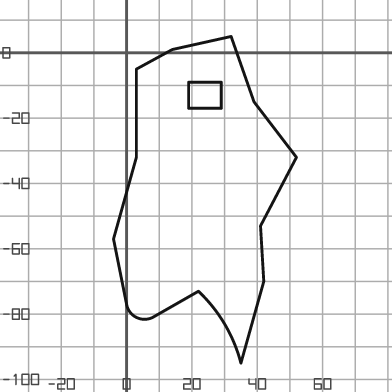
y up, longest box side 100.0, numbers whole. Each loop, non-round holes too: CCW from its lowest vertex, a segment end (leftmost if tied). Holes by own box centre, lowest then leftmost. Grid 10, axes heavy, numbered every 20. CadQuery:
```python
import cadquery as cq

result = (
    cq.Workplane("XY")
    .moveTo(35.0, -95.0)
    .lineTo(42.0, -70.0)
    .lineTo(41.0, -53.0)
    .lineTo(52.0, -32.0)
    .lineTo(39.0, -15.0)
    .lineTo(32.0, 5.0)
    .lineTo(14.0, 1.0)
    .lineTo(3.0, -5.0)
    .lineTo(3.0, -32.0)
    .lineTo(-4.0, -57.0)
    .lineTo(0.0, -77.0)
    .threePointArc((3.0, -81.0), (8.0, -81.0))
    .lineTo(22.0, -73.0)
    .threePointArc((30.0, -83.0), (35.0, -95.0))
    .close()
    .moveTo(19.0, -17.0)
    .lineTo(29.0, -17.0)
    .lineTo(29.0, -9.0)
    .lineTo(19.0, -9.0)
    .close()
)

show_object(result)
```